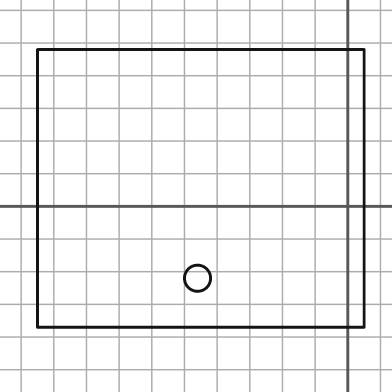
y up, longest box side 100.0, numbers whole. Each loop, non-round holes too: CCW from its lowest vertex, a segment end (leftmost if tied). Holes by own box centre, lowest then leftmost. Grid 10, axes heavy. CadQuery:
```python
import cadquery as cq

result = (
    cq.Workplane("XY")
    .moveTo(-95.0, -37.0)
    .lineTo(5.0, -37.0)
    .lineTo(5.0, 48.0)
    .lineTo(-95.0, 48.0)
    .close()
    .moveTo(-46.0, -22.0)
    .circle(4.0)
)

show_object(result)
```